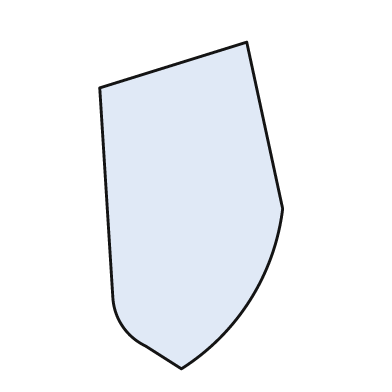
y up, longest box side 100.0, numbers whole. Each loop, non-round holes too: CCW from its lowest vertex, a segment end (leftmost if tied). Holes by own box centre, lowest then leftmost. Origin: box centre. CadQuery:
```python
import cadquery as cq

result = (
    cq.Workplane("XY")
    .moveTo(-3.0, -50.0)
    .threePointArc((18.0, -29.0), (28.0, -1.0))
    .lineTo(17.0, 50.0)
    .lineTo(-28.0, 36.0)
    .lineTo(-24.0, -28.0)
    .threePointArc((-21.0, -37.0), (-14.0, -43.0))
    .close()
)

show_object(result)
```